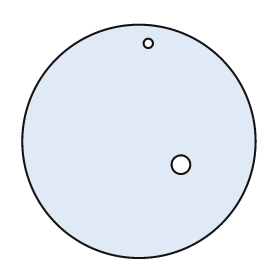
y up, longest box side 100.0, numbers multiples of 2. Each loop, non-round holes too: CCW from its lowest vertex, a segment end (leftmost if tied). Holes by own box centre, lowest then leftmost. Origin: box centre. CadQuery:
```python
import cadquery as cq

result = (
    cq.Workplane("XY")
    .moveTo(0.0, 0.0)
    .circle(50.0)
    .moveTo(18.0, -10.0)
    .circle(4.0)
    .moveTo(4.0, 42.0)
    .circle(2.0)
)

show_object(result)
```